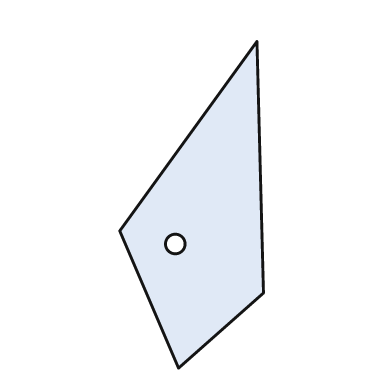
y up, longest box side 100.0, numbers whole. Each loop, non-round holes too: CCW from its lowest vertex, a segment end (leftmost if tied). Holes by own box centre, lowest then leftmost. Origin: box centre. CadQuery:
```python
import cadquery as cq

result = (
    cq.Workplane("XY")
    .moveTo(-4.0, -50.0)
    .lineTo(22.0, -27.0)
    .lineTo(20.0, 50.0)
    .lineTo(-22.0, -8.0)
    .close()
    .moveTo(-5.0, -12.0)
    .circle(3.0)
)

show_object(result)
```